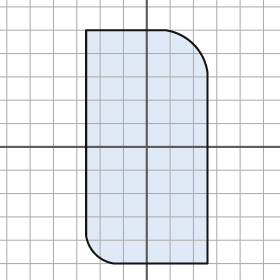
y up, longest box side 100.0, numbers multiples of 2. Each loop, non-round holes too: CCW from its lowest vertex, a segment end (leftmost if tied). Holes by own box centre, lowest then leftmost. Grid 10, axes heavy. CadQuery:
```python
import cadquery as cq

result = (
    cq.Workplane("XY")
    .moveTo(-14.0, -50.0)
    .lineTo(26.0, -50.0)
    .lineTo(26.0, 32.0)
    .threePointArc((20.0, 44.0), (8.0, 50.0))
    .lineTo(-26.0, 50.0)
    .lineTo(-26.0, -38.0)
    .threePointArc((-22.0, -46.0), (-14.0, -50.0))
    .close()
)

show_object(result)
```